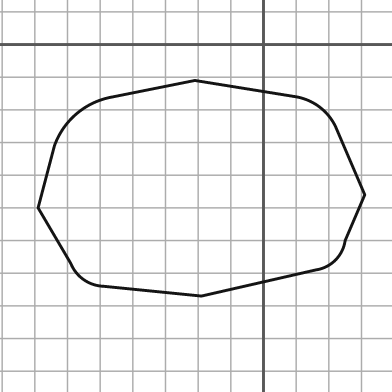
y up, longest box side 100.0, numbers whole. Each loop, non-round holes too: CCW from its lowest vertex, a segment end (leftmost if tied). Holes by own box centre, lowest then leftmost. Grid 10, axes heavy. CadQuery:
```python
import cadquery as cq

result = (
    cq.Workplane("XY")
    .moveTo(-19.0, -77.0)
    .lineTo(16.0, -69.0)
    .threePointArc((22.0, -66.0), (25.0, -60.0))
    .lineTo(31.0, -46.0)
    .lineTo(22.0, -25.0)
    .threePointArc((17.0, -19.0), (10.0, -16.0))
    .lineTo(-21.0, -11.0)
    .lineTo(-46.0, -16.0)
    .threePointArc((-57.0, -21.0), (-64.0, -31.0))
    .lineTo(-69.0, -50.0)
    .lineTo(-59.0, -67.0)
    .threePointArc((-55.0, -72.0), (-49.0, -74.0))
    .close()
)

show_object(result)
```